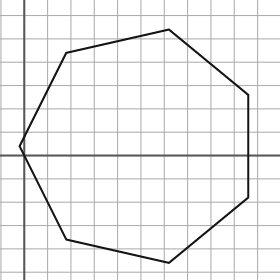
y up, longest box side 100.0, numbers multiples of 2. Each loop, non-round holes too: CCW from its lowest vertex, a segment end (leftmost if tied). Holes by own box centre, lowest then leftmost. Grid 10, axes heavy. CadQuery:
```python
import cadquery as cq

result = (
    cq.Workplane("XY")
    .moveTo(62.0, -46.0)
    .lineTo(96.0, -18.0)
    .lineTo(96.0, 26.0)
    .lineTo(62.0, 54.0)
    .lineTo(18.0, 44.0)
    .lineTo(-2.0, 4.0)
    .lineTo(18.0, -36.0)
    .close()
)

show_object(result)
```